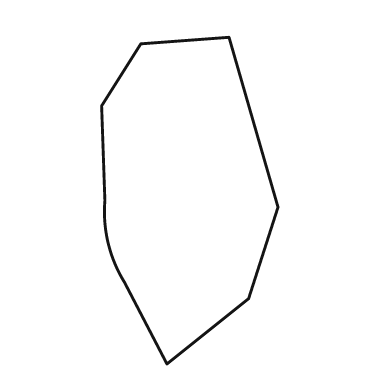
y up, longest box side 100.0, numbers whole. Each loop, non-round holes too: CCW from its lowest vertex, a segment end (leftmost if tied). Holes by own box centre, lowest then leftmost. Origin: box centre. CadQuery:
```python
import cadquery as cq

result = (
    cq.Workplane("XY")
    .moveTo(-7.0, -50.0)
    .lineTo(18.0, -30.0)
    .lineTo(27.0, -2.0)
    .lineTo(12.0, 50.0)
    .lineTo(-15.0, 48.0)
    .lineTo(-27.0, 29.0)
    .lineTo(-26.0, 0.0)
    .threePointArc((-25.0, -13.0), (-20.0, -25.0))
    .close()
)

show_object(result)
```